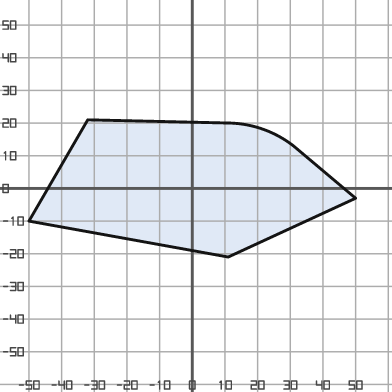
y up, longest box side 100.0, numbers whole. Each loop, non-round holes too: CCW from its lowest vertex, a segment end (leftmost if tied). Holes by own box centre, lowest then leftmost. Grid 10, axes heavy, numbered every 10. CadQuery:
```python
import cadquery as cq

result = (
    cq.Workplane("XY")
    .moveTo(11.0, -21.0)
    .lineTo(50.0, -3.0)
    .lineTo(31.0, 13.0)
    .threePointArc((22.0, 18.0), (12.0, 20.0))
    .lineTo(-32.0, 21.0)
    .lineTo(-50.0, -10.0)
    .close()
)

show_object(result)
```